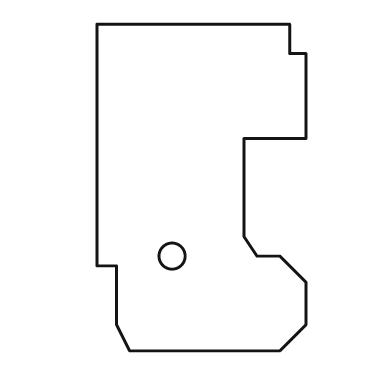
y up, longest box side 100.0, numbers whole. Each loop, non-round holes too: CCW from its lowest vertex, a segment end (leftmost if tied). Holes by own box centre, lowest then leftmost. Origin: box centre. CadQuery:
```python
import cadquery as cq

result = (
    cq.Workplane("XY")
    .moveTo(-22.0, -50.0)
    .lineTo(24.0, -50.0)
    .lineTo(32.0, -42.0)
    .lineTo(32.0, -29.0)
    .lineTo(24.0, -21.0)
    .lineTo(17.0, -21.0)
    .lineTo(13.0, -15.0)
    .lineTo(13.0, 15.0)
    .lineTo(32.0, 15.0)
    .lineTo(32.0, 41.0)
    .lineTo(27.0, 41.0)
    .lineTo(27.0, 50.0)
    .lineTo(-32.0, 50.0)
    .lineTo(-32.0, -24.0)
    .lineTo(-26.0, -24.0)
    .lineTo(-26.0, -42.0)
    .close()
    .moveTo(-9.0, -21.0)
    .circle(4.0)
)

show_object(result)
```